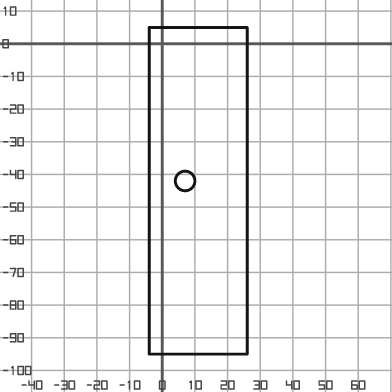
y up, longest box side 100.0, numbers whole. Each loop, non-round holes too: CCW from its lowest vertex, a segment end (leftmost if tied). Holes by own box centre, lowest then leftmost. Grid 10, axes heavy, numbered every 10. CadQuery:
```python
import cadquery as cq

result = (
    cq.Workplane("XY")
    .moveTo(-4.0, -95.0)
    .lineTo(26.0, -95.0)
    .lineTo(26.0, 5.0)
    .lineTo(-4.0, 5.0)
    .close()
    .moveTo(7.0, -42.0)
    .circle(3.0)
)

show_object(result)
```